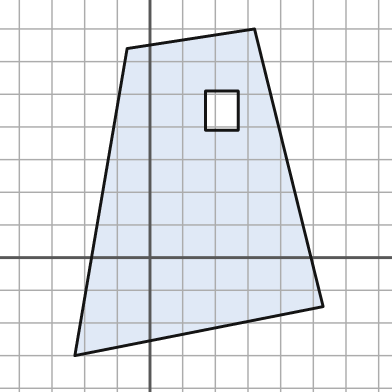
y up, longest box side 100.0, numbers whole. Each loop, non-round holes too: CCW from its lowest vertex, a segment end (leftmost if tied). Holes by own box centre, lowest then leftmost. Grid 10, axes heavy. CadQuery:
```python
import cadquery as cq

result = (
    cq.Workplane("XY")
    .moveTo(-23.0, -30.0)
    .lineTo(53.0, -15.0)
    .lineTo(32.0, 70.0)
    .lineTo(-7.0, 64.0)
    .close()
    .moveTo(17.0, 39.0)
    .lineTo(27.0, 39.0)
    .lineTo(27.0, 51.0)
    .lineTo(17.0, 51.0)
    .close()
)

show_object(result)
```